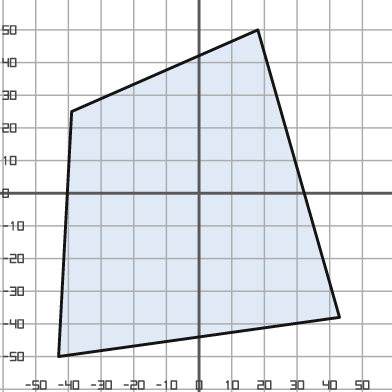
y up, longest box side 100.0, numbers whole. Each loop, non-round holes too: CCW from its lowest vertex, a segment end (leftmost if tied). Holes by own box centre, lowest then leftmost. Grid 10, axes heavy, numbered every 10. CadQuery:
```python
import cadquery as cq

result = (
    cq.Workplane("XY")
    .moveTo(-43.0, -50.0)
    .lineTo(43.0, -38.0)
    .lineTo(18.0, 50.0)
    .lineTo(-39.0, 25.0)
    .close()
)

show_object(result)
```